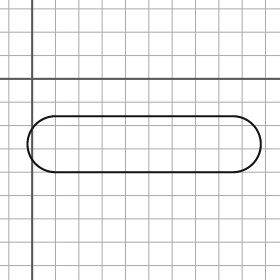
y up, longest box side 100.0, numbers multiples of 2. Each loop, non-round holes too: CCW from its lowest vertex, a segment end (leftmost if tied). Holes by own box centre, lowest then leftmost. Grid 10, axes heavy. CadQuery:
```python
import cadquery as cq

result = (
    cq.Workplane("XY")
    .moveTo(10.0, -40.0)
    .lineTo(86.0, -40.0)
    .threePointArc((98.0, -28.0), (86.0, -16.0))
    .lineTo(10.0, -16.0)
    .threePointArc((-2.0, -28.0), (10.0, -40.0))
    .close()
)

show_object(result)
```